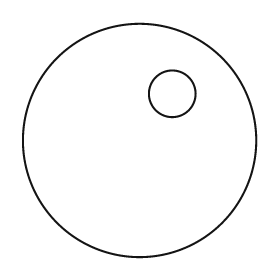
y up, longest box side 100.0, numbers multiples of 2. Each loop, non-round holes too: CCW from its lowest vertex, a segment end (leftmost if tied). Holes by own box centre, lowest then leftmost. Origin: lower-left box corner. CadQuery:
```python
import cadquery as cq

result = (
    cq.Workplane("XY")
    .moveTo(50.0, 50.0)
    .circle(50.0)
    .moveTo(64.0, 70.0)
    .circle(10.0)
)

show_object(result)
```